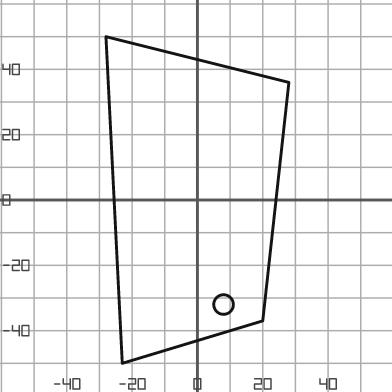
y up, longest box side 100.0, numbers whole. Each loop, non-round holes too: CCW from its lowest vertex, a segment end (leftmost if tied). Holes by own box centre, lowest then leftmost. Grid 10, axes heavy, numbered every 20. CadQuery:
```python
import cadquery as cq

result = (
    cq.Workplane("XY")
    .moveTo(-23.0, -50.0)
    .lineTo(20.0, -37.0)
    .lineTo(28.0, 36.0)
    .lineTo(-28.0, 50.0)
    .close()
    .moveTo(8.0, -32.0)
    .circle(3.0)
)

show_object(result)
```